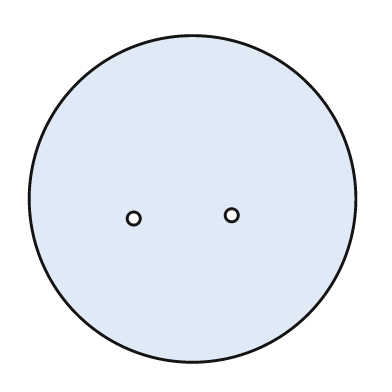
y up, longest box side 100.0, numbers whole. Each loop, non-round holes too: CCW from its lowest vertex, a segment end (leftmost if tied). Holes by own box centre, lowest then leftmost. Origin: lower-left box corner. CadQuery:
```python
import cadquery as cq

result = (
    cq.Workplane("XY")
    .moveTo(50.0, 50.0)
    .circle(50.0)
    .moveTo(32.0, 44.0)
    .circle(2.0)
    .moveTo(62.0, 45.0)
    .circle(2.0)
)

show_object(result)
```